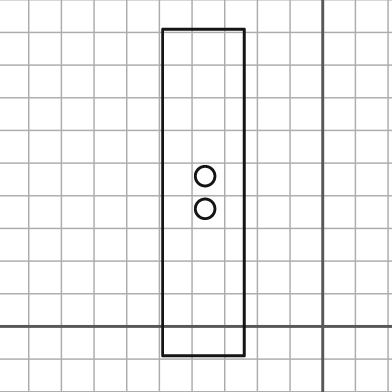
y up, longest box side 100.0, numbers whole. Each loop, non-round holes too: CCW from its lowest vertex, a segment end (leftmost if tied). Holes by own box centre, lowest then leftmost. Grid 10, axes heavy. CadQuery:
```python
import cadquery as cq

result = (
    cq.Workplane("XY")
    .moveTo(-49.0, -9.0)
    .lineTo(-24.0, -9.0)
    .lineTo(-24.0, 91.0)
    .lineTo(-49.0, 91.0)
    .close()
    .moveTo(-36.0, 36.0)
    .circle(3.0)
    .moveTo(-36.0, 46.0)
    .circle(3.0)
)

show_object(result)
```